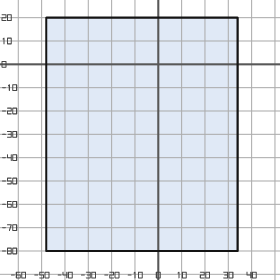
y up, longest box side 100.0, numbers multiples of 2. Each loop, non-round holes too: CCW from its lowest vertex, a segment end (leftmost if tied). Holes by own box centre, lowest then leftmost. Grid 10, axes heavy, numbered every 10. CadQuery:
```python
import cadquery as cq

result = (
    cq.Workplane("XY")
    .moveTo(-48.0, -80.0)
    .lineTo(34.0, -80.0)
    .lineTo(34.0, 20.0)
    .lineTo(-48.0, 20.0)
    .close()
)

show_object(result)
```